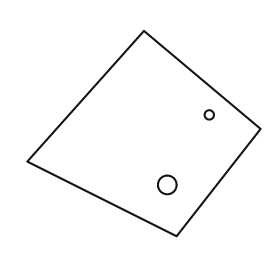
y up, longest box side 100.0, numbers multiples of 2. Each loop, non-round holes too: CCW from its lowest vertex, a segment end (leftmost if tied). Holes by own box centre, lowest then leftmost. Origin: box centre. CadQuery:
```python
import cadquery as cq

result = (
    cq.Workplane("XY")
    .moveTo(14.0, -44.0)
    .lineTo(50.0, 2.0)
    .lineTo(0.0, 44.0)
    .lineTo(-50.0, -12.0)
    .close()
    .moveTo(10.0, -22.0)
    .circle(4.0)
    .moveTo(28.0, 8.0)
    .circle(2.0)
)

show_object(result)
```